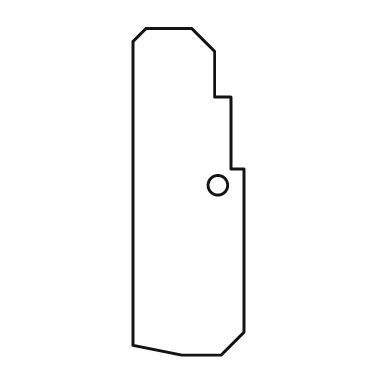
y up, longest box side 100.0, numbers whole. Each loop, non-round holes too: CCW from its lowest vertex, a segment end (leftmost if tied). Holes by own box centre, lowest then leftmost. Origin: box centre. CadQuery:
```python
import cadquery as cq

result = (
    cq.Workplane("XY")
    .moveTo(-2.0, -50.0)
    .lineTo(10.0, -50.0)
    .lineTo(17.0, -43.0)
    .lineTo(17.0, 7.0)
    .lineTo(13.0, 7.0)
    .lineTo(13.0, 29.0)
    .lineTo(8.0, 29.0)
    .lineTo(8.0, 43.0)
    .lineTo(1.0, 50.0)
    .lineTo(-13.0, 50.0)
    .lineTo(-17.0, 46.0)
    .lineTo(-17.0, -47.0)
    .close()
    .moveTo(9.0, 2.0)
    .circle(3.0)
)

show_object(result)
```